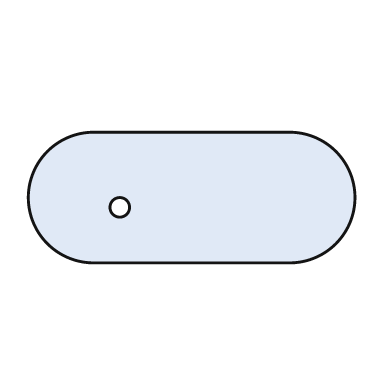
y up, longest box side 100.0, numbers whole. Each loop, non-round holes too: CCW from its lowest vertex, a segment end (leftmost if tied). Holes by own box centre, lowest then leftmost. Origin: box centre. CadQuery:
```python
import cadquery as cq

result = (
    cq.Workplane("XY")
    .moveTo(-30.0, -20.0)
    .lineTo(30.0, -20.0)
    .threePointArc((50.0, 0.0), (30.0, 20.0))
    .lineTo(-30.0, 20.0)
    .threePointArc((-50.0, 0.0), (-30.0, -20.0))
    .close()
    .moveTo(-22.0, -3.0)
    .circle(3.0)
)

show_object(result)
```